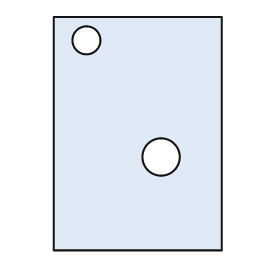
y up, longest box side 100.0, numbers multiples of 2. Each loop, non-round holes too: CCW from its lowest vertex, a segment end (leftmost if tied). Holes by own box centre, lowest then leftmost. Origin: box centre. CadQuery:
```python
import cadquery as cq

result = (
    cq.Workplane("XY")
    .moveTo(-36.0, -50.0)
    .lineTo(36.0, -50.0)
    .lineTo(36.0, 50.0)
    .lineTo(-36.0, 50.0)
    .close()
    .moveTo(10.0, -10.0)
    .circle(8.0)
    .moveTo(-22.0, 40.0)
    .circle(6.0)
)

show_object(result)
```